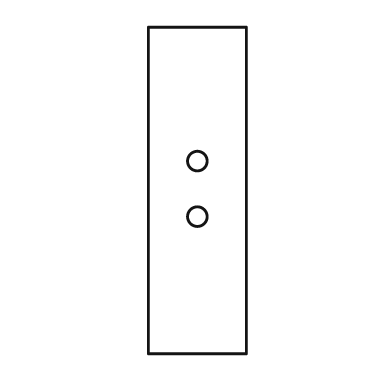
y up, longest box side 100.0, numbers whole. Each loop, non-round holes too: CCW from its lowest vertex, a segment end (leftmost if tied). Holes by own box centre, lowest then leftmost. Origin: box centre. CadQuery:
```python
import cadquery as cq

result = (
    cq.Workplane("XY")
    .moveTo(-15.0, -50.0)
    .lineTo(15.0, -50.0)
    .lineTo(15.0, 50.0)
    .lineTo(-15.0, 50.0)
    .close()
    .moveTo(0.0, -8.0)
    .circle(3.0)
    .moveTo(0.0, 9.0)
    .circle(3.0)
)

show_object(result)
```